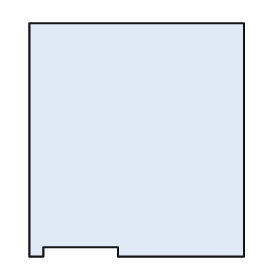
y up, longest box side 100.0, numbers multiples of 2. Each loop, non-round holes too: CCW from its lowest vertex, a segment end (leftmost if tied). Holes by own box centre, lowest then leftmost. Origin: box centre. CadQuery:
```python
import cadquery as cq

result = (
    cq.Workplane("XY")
    .moveTo(-46.0, -50.0)
    .lineTo(-40.0, -50.0)
    .lineTo(-40.0, -46.0)
    .lineTo(-8.0, -46.0)
    .lineTo(-8.0, -50.0)
    .lineTo(46.0, -50.0)
    .lineTo(46.0, 50.0)
    .lineTo(-46.0, 50.0)
    .close()
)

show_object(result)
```